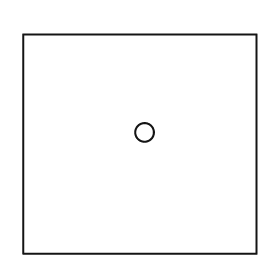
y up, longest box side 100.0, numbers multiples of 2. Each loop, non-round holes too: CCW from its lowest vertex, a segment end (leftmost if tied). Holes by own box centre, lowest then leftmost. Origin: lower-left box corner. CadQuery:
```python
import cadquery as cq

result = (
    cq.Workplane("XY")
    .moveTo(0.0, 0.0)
    .lineTo(100.0, 0.0)
    .lineTo(100.0, 94.0)
    .lineTo(0.0, 94.0)
    .close()
    .moveTo(52.0, 52.0)
    .circle(4.0)
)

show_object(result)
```